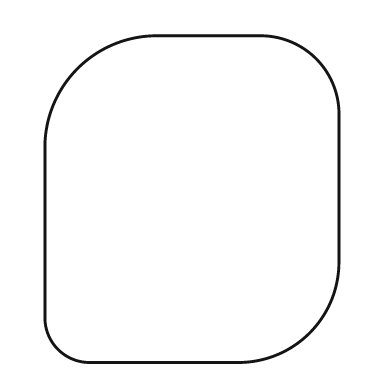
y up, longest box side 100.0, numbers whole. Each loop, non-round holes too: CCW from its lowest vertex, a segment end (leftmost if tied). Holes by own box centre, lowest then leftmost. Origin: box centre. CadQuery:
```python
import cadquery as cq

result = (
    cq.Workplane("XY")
    .moveTo(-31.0, -50.0)
    .lineTo(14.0, -50.0)
    .threePointArc((36.0, -41.0), (45.0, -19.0))
    .lineTo(45.0, 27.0)
    .threePointArc((38.0, 43.0), (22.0, 50.0))
    .lineTo(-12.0, 50.0)
    .threePointArc((-35.0, 40.0), (-45.0, 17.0))
    .lineTo(-45.0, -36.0)
    .threePointArc((-41.0, -46.0), (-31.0, -50.0))
    .close()
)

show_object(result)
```